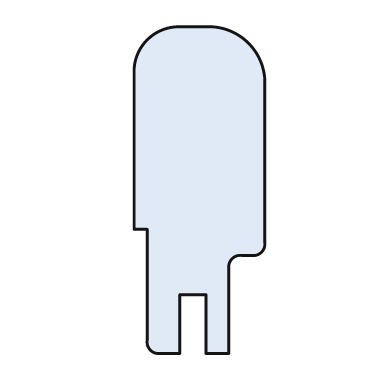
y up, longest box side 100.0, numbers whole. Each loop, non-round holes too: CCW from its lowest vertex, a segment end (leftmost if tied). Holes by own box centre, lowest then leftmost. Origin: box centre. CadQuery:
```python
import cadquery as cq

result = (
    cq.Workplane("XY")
    .moveTo(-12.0, -50.0)
    .lineTo(-6.0, -50.0)
    .lineTo(-6.0, -32.0)
    .lineTo(2.0, -32.0)
    .lineTo(2.0, -50.0)
    .lineTo(9.0, -50.0)
    .lineTo(9.0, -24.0)
    .threePointArc((10.0, -21.0), (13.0, -20.0))
    .lineTo(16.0, -20.0)
    .threePointArc((19.0, -19.0), (20.0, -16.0))
    .lineTo(20.0, 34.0)
    .threePointArc((15.0, 45.0), (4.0, 50.0))
    .lineTo(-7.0, 50.0)
    .threePointArc((-16.0, 46.0), (-20.0, 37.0))
    .lineTo(-20.0, -12.0)
    .lineTo(-16.0, -12.0)
    .lineTo(-16.0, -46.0)
    .threePointArc((-15.0, -49.0), (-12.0, -50.0))
    .close()
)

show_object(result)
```